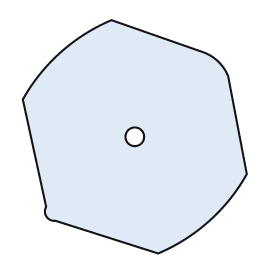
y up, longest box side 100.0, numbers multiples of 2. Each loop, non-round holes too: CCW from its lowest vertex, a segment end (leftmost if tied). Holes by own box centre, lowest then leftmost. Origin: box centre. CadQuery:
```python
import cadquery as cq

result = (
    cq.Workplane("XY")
    .moveTo(10.0, -50.0)
    .threePointArc((32.0, -36.0), (48.0, -16.0))
    .lineTo(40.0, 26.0)
    .threePointArc((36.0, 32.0), (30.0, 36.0))
    .lineTo(-10.0, 50.0)
    .threePointArc((-32.0, 36.0), (-48.0, 16.0))
    .lineTo(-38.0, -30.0)
    .threePointArc((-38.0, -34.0), (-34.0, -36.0))
    .close()
    .moveTo(0.0, 0.0)
    .circle(4.0)
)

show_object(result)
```